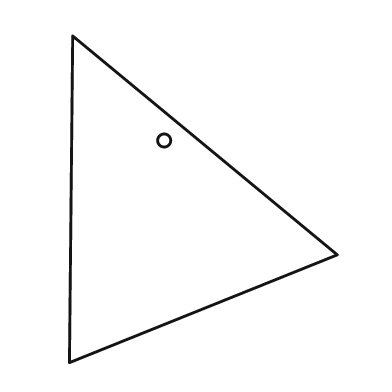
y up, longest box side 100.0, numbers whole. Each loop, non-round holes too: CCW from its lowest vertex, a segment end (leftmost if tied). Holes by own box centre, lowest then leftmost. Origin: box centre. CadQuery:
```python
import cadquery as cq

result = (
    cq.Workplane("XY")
    .moveTo(-41.0, -50.0)
    .lineTo(41.0, -17.0)
    .lineTo(-40.0, 50.0)
    .close()
    .moveTo(-12.0, 18.0)
    .circle(2.0)
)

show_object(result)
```